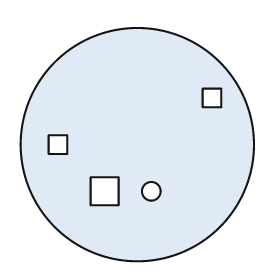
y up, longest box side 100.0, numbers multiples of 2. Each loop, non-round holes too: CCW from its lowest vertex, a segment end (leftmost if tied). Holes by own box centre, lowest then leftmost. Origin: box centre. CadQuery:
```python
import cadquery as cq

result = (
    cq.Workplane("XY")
    .moveTo(0.0, 0.0)
    .circle(50.0)
    .moveTo(-20.0, -26.0)
    .lineTo(-8.0, -26.0)
    .lineTo(-8.0, -14.0)
    .lineTo(-20.0, -14.0)
    .close()
    .moveTo(6.0, -20.0)
    .circle(4.0)
    .moveTo(-38.0, -4.0)
    .lineTo(-30.0, -4.0)
    .lineTo(-30.0, 4.0)
    .lineTo(-38.0, 4.0)
    .close()
    .moveTo(28.0, 16.0)
    .lineTo(36.0, 16.0)
    .lineTo(36.0, 24.0)
    .lineTo(28.0, 24.0)
    .close()
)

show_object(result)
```